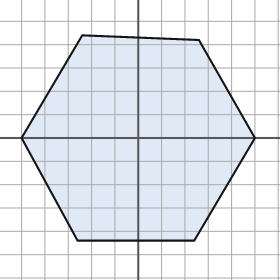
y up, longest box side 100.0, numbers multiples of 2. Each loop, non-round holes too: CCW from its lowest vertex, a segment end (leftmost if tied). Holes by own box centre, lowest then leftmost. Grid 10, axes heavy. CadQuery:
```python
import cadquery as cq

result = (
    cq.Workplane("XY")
    .moveTo(-26.0, -44.0)
    .lineTo(24.0, -44.0)
    .lineTo(50.0, 0.0)
    .lineTo(26.0, 42.0)
    .lineTo(-24.0, 44.0)
    .lineTo(-50.0, 0.0)
    .close()
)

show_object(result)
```